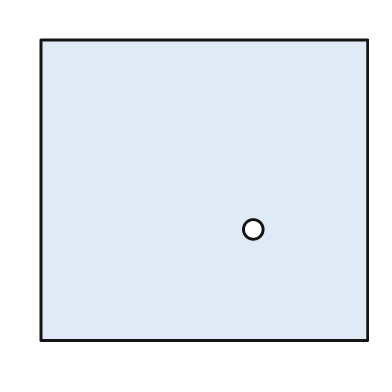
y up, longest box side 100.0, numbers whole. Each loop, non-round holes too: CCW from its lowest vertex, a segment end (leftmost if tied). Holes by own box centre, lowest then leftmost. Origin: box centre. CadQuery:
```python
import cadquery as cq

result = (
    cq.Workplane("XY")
    .moveTo(-50.0, -46.0)
    .lineTo(50.0, -46.0)
    .lineTo(50.0, 46.0)
    .lineTo(-50.0, 46.0)
    .close()
    .moveTo(15.0, -12.0)
    .circle(3.0)
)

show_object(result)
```